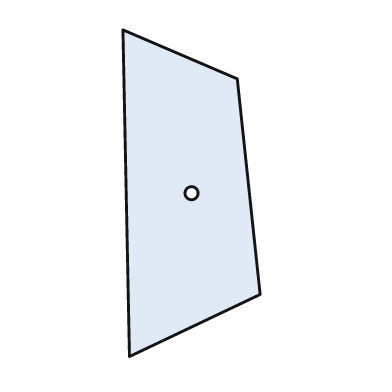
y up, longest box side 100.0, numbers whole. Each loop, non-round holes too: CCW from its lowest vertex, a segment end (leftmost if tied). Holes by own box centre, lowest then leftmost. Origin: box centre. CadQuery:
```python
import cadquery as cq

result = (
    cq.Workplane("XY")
    .moveTo(-19.0, -50.0)
    .lineTo(21.0, -31.0)
    .lineTo(14.0, 35.0)
    .lineTo(-21.0, 50.0)
    .close()
    .moveTo(0.0, 0.0)
    .circle(2.0)
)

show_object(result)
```